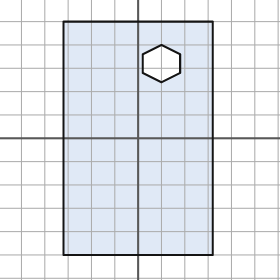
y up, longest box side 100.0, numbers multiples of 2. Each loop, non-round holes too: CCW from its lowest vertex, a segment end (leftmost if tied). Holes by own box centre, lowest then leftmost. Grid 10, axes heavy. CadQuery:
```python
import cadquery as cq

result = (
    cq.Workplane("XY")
    .moveTo(-32.0, -50.0)
    .lineTo(32.0, -50.0)
    .lineTo(32.0, 50.0)
    .lineTo(-32.0, 50.0)
    .close()
    .moveTo(10.0, 24.0)
    .lineTo(18.0, 28.0)
    .lineTo(18.0, 36.0)
    .lineTo(10.0, 40.0)
    .lineTo(2.0, 36.0)
    .lineTo(2.0, 28.0)
    .close()
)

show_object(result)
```